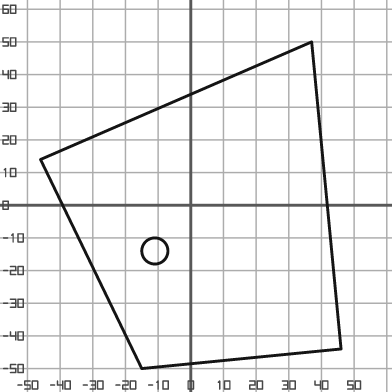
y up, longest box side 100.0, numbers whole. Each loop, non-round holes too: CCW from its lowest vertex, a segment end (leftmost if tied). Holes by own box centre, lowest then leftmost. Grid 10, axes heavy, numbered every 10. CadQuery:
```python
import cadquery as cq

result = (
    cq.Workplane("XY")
    .moveTo(-15.0, -50.0)
    .lineTo(46.0, -44.0)
    .lineTo(37.0, 50.0)
    .lineTo(-46.0, 14.0)
    .close()
    .moveTo(-11.0, -14.0)
    .circle(4.0)
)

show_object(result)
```